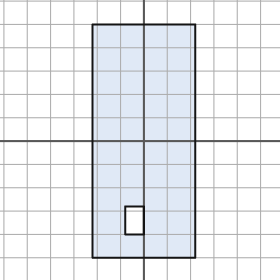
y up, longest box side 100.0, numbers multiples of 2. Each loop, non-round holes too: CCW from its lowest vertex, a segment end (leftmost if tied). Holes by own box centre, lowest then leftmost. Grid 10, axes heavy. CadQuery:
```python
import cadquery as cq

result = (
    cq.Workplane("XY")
    .moveTo(-22.0, -50.0)
    .lineTo(22.0, -50.0)
    .lineTo(22.0, 50.0)
    .lineTo(-22.0, 50.0)
    .close()
    .moveTo(-8.0, -40.0)
    .lineTo(0.0, -40.0)
    .lineTo(0.0, -28.0)
    .lineTo(-8.0, -28.0)
    .close()
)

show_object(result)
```